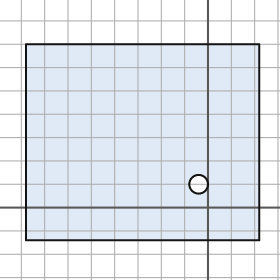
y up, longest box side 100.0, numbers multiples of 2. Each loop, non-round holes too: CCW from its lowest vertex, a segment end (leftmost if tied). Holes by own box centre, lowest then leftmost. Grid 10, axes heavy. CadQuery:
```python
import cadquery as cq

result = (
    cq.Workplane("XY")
    .moveTo(-78.0, -14.0)
    .lineTo(22.0, -14.0)
    .lineTo(22.0, 70.0)
    .lineTo(-78.0, 70.0)
    .close()
    .moveTo(-4.0, 10.0)
    .circle(4.0)
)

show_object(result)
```